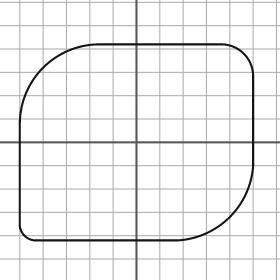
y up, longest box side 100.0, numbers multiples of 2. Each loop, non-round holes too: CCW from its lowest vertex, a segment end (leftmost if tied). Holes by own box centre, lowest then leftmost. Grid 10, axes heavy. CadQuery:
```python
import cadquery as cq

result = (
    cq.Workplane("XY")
    .moveTo(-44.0, -42.0)
    .lineTo(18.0, -42.0)
    .threePointArc((40.0, -32.0), (50.0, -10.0))
    .lineTo(50.0, 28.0)
    .threePointArc((46.0, 38.0), (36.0, 42.0))
    .lineTo(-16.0, 42.0)
    .threePointArc((-40.0, 32.0), (-50.0, 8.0))
    .lineTo(-50.0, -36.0)
    .threePointArc((-48.0, -40.0), (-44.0, -42.0))
    .close()
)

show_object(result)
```